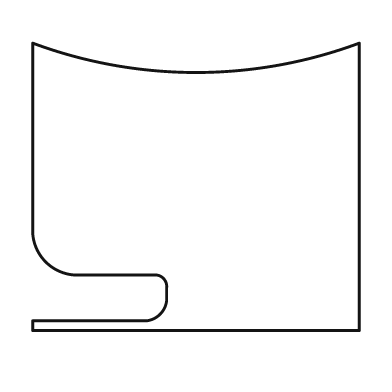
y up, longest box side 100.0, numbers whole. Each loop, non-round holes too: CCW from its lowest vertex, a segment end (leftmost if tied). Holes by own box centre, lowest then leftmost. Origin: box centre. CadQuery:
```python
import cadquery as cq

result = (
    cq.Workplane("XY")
    .moveTo(-50.0, -44.0)
    .lineTo(50.0, -44.0)
    .lineTo(50.0, 44.0)
    .threePointArc((0.0, 35.0), (-50.0, 44.0))
    .lineTo(-50.0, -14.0)
    .threePointArc((-46.0, -23.0), (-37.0, -27.0))
    .lineTo(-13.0, -27.0)
    .threePointArc((-10.0, -28.0), (-9.0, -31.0))
    .lineTo(-9.0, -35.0)
    .threePointArc((-11.0, -39.0), (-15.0, -41.0))
    .lineTo(-50.0, -41.0)
    .close()
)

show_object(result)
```